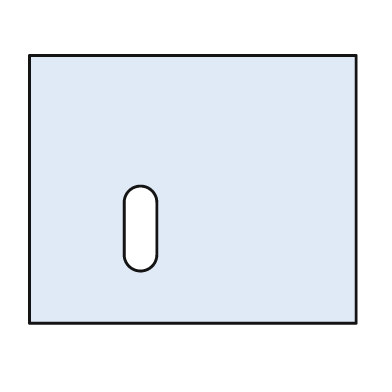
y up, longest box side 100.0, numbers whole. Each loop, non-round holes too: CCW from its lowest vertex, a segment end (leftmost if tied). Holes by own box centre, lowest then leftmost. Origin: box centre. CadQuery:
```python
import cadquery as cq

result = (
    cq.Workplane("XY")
    .moveTo(-50.0, -41.0)
    .lineTo(50.0, -41.0)
    .lineTo(50.0, 41.0)
    .lineTo(-50.0, 41.0)
    .close()
    .moveTo(-21.0, -20.0)
    .threePointArc((-16.0, -25.0), (-11.0, -20.0))
    .lineTo(-11.0, -4.0)
    .threePointArc((-16.0, 1.0), (-21.0, -4.0))
    .close()
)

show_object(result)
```